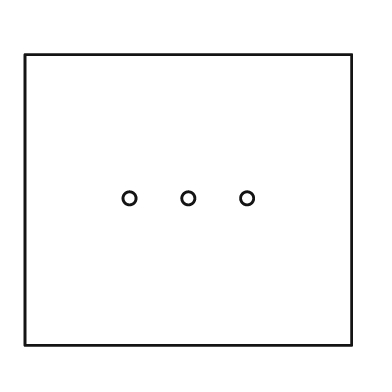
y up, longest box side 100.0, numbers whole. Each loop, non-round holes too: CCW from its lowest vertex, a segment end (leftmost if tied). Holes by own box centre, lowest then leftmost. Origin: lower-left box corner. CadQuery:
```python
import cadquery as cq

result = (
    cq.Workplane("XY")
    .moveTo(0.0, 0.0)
    .lineTo(100.0, 0.0)
    .lineTo(100.0, 89.0)
    .lineTo(0.0, 89.0)
    .close()
    .moveTo(32.0, 45.0)
    .circle(2.0)
    .moveTo(50.0, 45.0)
    .circle(2.0)
    .moveTo(68.0, 45.0)
    .circle(2.0)
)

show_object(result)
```